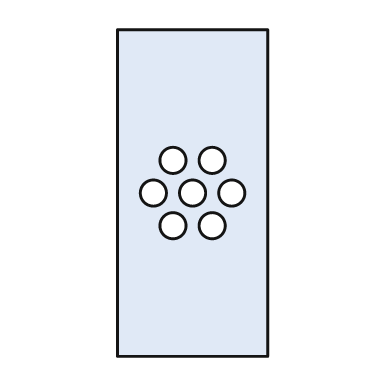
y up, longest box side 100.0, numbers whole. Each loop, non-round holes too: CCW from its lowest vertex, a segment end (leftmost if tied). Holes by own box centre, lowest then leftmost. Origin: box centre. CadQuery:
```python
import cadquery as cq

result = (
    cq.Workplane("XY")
    .moveTo(-23.0, -50.0)
    .lineTo(23.0, -50.0)
    .lineTo(23.0, 50.0)
    .lineTo(-23.0, 50.0)
    .close()
    .moveTo(-6.0, -10.0)
    .circle(4.0)
    .moveTo(6.0, -10.0)
    .circle(4.0)
    .moveTo(-12.0, 0.0)
    .circle(4.0)
    .moveTo(0.0, 0.0)
    .circle(4.0)
    .moveTo(12.0, 0.0)
    .circle(4.0)
    .moveTo(-6.0, 10.0)
    .circle(4.0)
    .moveTo(6.0, 10.0)
    .circle(4.0)
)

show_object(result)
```